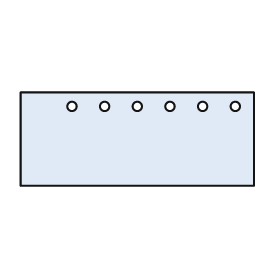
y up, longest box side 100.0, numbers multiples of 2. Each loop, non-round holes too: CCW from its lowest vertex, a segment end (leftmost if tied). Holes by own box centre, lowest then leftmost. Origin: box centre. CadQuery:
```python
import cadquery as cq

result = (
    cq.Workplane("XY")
    .moveTo(-50.0, -20.0)
    .lineTo(50.0, -20.0)
    .lineTo(50.0, 20.0)
    .lineTo(-50.0, 20.0)
    .close()
    .moveTo(-28.0, 14.0)
    .circle(2.0)
    .moveTo(-14.0, 14.0)
    .circle(2.0)
    .moveTo(0.0, 14.0)
    .circle(2.0)
    .moveTo(14.0, 14.0)
    .circle(2.0)
    .moveTo(28.0, 14.0)
    .circle(2.0)
    .moveTo(42.0, 14.0)
    .circle(2.0)
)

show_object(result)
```